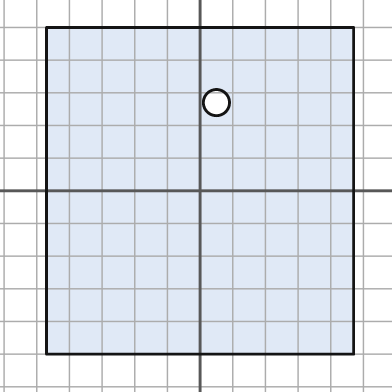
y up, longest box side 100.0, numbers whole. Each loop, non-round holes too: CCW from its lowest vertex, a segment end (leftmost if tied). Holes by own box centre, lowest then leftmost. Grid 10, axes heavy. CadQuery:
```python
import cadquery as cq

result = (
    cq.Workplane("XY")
    .moveTo(-47.0, -50.0)
    .lineTo(47.0, -50.0)
    .lineTo(47.0, 50.0)
    .lineTo(-47.0, 50.0)
    .close()
    .moveTo(5.0, 27.0)
    .circle(4.0)
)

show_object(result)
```